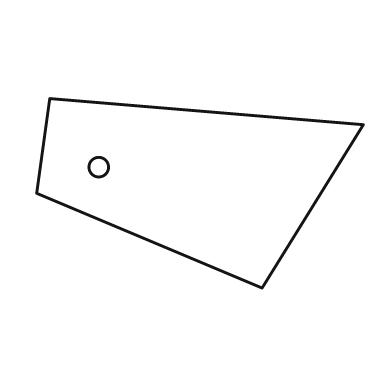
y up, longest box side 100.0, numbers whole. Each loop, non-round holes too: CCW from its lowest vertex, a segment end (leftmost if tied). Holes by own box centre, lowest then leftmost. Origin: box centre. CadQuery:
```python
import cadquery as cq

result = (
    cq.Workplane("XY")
    .moveTo(19.0, -29.0)
    .lineTo(50.0, 21.0)
    .lineTo(-46.0, 29.0)
    .lineTo(-50.0, 0.0)
    .close()
    .moveTo(-31.0, 8.0)
    .circle(3.0)
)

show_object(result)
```